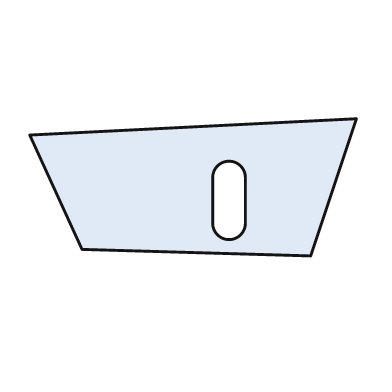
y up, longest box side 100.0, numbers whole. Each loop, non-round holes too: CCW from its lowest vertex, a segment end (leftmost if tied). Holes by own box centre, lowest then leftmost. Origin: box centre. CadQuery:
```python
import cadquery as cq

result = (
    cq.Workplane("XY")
    .moveTo(36.0, -21.0)
    .lineTo(50.0, 21.0)
    .lineTo(-50.0, 16.0)
    .lineTo(-34.0, -19.0)
    .close()
    .moveTo(6.0, -11.0)
    .threePointArc((11.0, -16.0), (16.0, -11.0))
    .lineTo(16.0, 3.0)
    .threePointArc((11.0, 8.0), (6.0, 3.0))
    .close()
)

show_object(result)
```